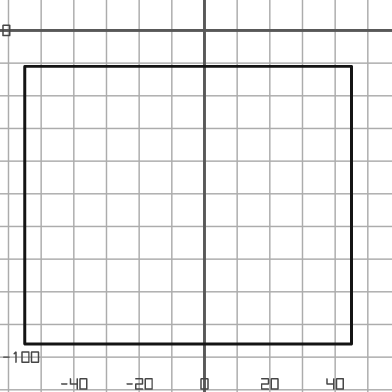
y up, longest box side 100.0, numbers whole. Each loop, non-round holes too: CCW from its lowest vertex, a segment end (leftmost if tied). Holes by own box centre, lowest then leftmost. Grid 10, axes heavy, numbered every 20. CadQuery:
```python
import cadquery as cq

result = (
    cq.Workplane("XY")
    .moveTo(-55.0, -96.0)
    .lineTo(45.0, -96.0)
    .lineTo(45.0, -11.0)
    .lineTo(-55.0, -11.0)
    .close()
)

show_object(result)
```